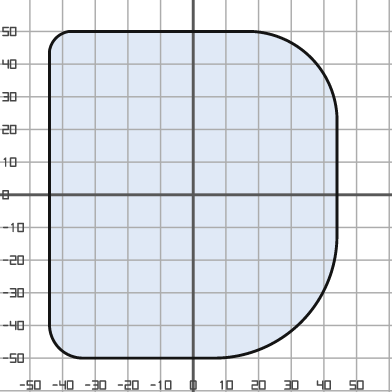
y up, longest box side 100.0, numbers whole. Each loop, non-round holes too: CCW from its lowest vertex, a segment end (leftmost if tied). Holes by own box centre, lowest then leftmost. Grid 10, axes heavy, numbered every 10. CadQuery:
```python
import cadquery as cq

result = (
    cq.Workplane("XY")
    .moveTo(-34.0, -50.0)
    .lineTo(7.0, -50.0)
    .threePointArc((33.0, -39.0), (44.0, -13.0))
    .lineTo(44.0, 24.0)
    .threePointArc((36.0, 42.0), (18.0, 50.0))
    .lineTo(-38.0, 50.0)
    .threePointArc((-42.0, 48.0), (-44.0, 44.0))
    .lineTo(-44.0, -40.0)
    .threePointArc((-41.0, -47.0), (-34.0, -50.0))
    .close()
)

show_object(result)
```